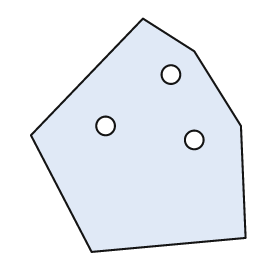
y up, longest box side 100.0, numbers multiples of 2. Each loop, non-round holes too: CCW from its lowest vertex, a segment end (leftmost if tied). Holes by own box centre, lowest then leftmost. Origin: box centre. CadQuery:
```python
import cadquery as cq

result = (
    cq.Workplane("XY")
    .moveTo(-20.0, -50.0)
    .lineTo(46.0, -44.0)
    .lineTo(44.0, 4.0)
    .lineTo(24.0, 36.0)
    .lineTo(2.0, 50.0)
    .lineTo(-46.0, 0.0)
    .close()
    .moveTo(24.0, -2.0)
    .circle(4.0)
    .moveTo(-14.0, 4.0)
    .circle(4.0)
    .moveTo(14.0, 26.0)
    .circle(4.0)
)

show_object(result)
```